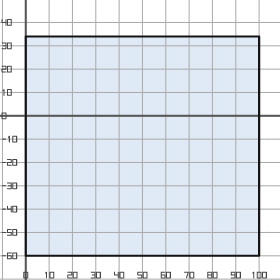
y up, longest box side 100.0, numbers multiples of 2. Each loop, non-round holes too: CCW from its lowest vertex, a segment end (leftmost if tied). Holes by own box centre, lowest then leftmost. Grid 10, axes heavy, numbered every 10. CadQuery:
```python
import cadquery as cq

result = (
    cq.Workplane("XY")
    .moveTo(0.0, -60.0)
    .lineTo(100.0, -60.0)
    .lineTo(100.0, 34.0)
    .lineTo(0.0, 34.0)
    .close()
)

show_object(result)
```